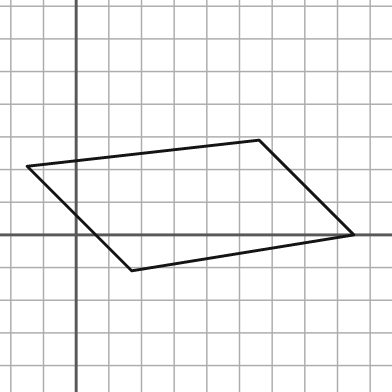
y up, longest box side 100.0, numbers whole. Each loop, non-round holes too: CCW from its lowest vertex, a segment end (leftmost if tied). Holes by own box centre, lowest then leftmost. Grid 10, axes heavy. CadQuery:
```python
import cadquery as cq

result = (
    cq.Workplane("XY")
    .moveTo(17.0, -11.0)
    .lineTo(85.0, 0.0)
    .lineTo(56.0, 29.0)
    .lineTo(-15.0, 21.0)
    .close()
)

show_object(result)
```